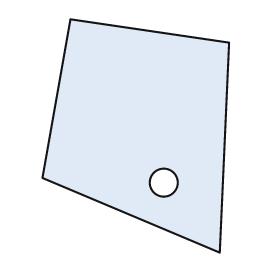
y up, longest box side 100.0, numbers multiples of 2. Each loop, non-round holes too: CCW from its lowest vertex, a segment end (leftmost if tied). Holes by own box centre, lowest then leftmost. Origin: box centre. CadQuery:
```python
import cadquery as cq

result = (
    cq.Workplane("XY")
    .moveTo(36.0, -50.0)
    .lineTo(40.0, 40.0)
    .lineTo(-28.0, 50.0)
    .lineTo(-40.0, -18.0)
    .close()
    .moveTo(12.0, -20.0)
    .circle(6.0)
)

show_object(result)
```